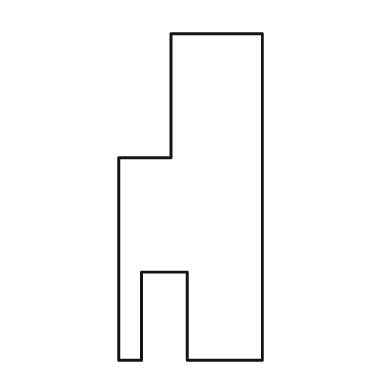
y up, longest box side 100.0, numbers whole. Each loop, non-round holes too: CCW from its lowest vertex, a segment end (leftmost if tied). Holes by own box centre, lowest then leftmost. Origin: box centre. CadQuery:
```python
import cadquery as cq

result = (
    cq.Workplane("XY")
    .moveTo(-22.0, -50.0)
    .lineTo(-15.0, -50.0)
    .lineTo(-15.0, -23.0)
    .lineTo(-1.0, -23.0)
    .lineTo(-1.0, -50.0)
    .lineTo(22.0, -50.0)
    .lineTo(22.0, 50.0)
    .lineTo(-6.0, 50.0)
    .lineTo(-6.0, 12.0)
    .lineTo(-22.0, 12.0)
    .close()
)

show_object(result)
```